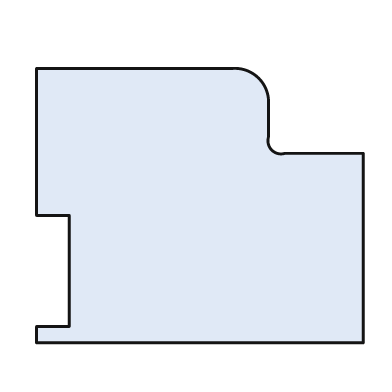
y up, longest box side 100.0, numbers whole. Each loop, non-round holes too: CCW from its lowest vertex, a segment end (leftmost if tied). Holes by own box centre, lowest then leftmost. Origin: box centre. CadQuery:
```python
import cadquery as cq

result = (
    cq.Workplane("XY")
    .moveTo(-50.0, -42.0)
    .lineTo(50.0, -42.0)
    .lineTo(50.0, 16.0)
    .lineTo(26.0, 16.0)
    .threePointArc((22.0, 17.0), (21.0, 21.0))
    .lineTo(21.0, 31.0)
    .threePointArc((18.0, 39.0), (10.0, 42.0))
    .lineTo(-50.0, 42.0)
    .lineTo(-50.0, -3.0)
    .lineTo(-40.0, -3.0)
    .lineTo(-40.0, -37.0)
    .lineTo(-50.0, -37.0)
    .close()
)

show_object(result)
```